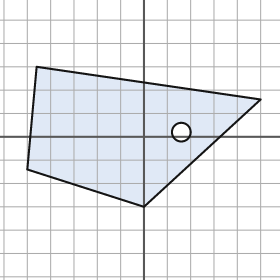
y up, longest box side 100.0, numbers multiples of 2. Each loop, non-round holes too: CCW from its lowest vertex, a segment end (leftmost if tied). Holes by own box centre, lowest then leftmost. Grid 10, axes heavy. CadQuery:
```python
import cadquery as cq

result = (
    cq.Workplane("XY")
    .moveTo(0.0, -30.0)
    .lineTo(50.0, 16.0)
    .lineTo(-46.0, 30.0)
    .lineTo(-50.0, -14.0)
    .close()
    .moveTo(16.0, 2.0)
    .circle(4.0)
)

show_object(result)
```